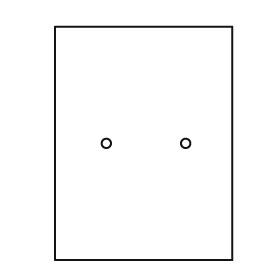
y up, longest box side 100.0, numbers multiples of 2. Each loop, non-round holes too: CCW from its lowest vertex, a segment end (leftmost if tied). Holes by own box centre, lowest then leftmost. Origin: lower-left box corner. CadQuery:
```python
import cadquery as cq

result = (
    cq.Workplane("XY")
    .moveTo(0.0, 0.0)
    .lineTo(76.0, 0.0)
    .lineTo(76.0, 100.0)
    .lineTo(0.0, 100.0)
    .close()
    .moveTo(22.0, 50.0)
    .circle(2.0)
    .moveTo(56.0, 50.0)
    .circle(2.0)
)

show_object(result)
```